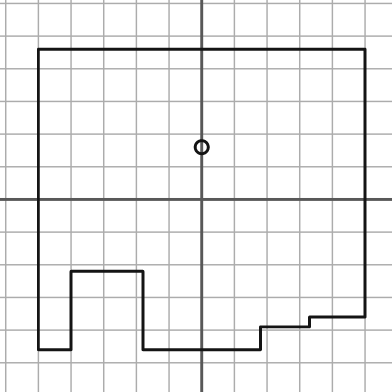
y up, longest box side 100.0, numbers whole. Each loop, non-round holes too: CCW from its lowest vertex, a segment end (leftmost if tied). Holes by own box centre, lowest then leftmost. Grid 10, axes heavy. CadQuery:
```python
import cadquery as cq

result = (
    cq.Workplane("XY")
    .moveTo(-50.0, -46.0)
    .lineTo(-40.0, -46.0)
    .lineTo(-40.0, -22.0)
    .lineTo(-18.0, -22.0)
    .lineTo(-18.0, -46.0)
    .lineTo(18.0, -46.0)
    .lineTo(18.0, -39.0)
    .lineTo(33.0, -39.0)
    .lineTo(33.0, -36.0)
    .lineTo(50.0, -36.0)
    .lineTo(50.0, 46.0)
    .lineTo(-50.0, 46.0)
    .close()
    .moveTo(0.0, 16.0)
    .circle(2.0)
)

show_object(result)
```